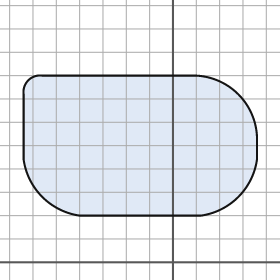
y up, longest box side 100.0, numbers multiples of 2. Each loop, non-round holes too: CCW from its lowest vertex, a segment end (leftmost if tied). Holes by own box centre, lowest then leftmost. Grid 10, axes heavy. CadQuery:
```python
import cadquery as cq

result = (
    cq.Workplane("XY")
    .moveTo(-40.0, 20.0)
    .lineTo(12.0, 20.0)
    .threePointArc((28.0, 28.0), (36.0, 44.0))
    .lineTo(36.0, 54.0)
    .threePointArc((28.0, 72.0), (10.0, 80.0))
    .lineTo(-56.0, 80.0)
    .threePointArc((-62.0, 78.0), (-64.0, 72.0))
    .lineTo(-64.0, 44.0)
    .threePointArc((-56.0, 28.0), (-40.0, 20.0))
    .close()
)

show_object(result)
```